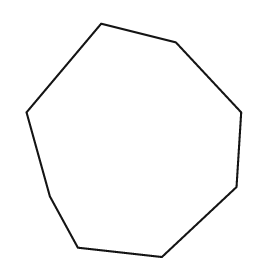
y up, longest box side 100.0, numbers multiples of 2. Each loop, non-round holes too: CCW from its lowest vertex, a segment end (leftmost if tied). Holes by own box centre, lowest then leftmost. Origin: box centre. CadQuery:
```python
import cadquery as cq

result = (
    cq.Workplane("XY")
    .moveTo(12.0, -50.0)
    .lineTo(44.0, -20.0)
    .lineTo(46.0, 12.0)
    .lineTo(18.0, 42.0)
    .lineTo(-14.0, 50.0)
    .lineTo(-46.0, 12.0)
    .lineTo(-36.0, -24.0)
    .lineTo(-24.0, -46.0)
    .close()
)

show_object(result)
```